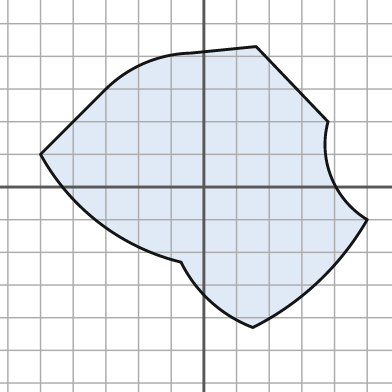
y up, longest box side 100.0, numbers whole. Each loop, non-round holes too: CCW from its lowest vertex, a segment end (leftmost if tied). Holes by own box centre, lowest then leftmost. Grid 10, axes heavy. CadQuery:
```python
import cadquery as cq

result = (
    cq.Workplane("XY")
    .moveTo(15.0, -43.0)
    .threePointArc((35.0, -29.0), (50.0, -10.0))
    .threePointArc((39.0, 3.0), (38.0, 20.0))
    .lineTo(16.0, 43.0)
    .lineTo(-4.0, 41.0)
    .threePointArc((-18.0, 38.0), (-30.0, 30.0))
    .lineTo(-50.0, 10.0)
    .threePointArc((-32.0, -11.0), (-7.0, -23.0))
    .threePointArc((2.0, -35.0), (15.0, -43.0))
    .close()
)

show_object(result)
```